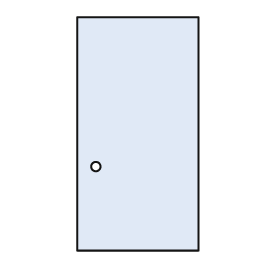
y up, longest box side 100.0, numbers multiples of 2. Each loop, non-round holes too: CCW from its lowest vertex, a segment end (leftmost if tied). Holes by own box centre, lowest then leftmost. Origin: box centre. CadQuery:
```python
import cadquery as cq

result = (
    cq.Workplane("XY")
    .moveTo(-26.0, -50.0)
    .lineTo(26.0, -50.0)
    .lineTo(26.0, 50.0)
    .lineTo(-26.0, 50.0)
    .close()
    .moveTo(-18.0, -14.0)
    .circle(2.0)
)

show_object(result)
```